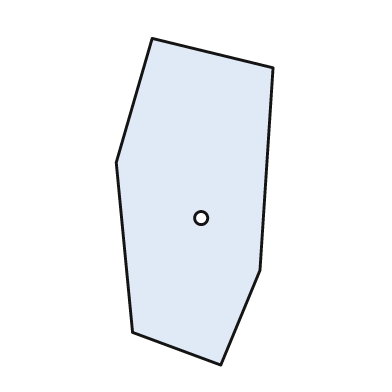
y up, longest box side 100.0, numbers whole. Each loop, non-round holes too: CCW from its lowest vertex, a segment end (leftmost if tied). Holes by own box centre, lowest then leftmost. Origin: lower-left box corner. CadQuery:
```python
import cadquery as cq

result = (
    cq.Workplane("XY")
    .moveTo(32.0, 0.0)
    .lineTo(44.0, 29.0)
    .lineTo(48.0, 91.0)
    .lineTo(11.0, 100.0)
    .lineTo(0.0, 62.0)
    .lineTo(5.0, 10.0)
    .close()
    .moveTo(26.0, 45.0)
    .circle(2.0)
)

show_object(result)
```